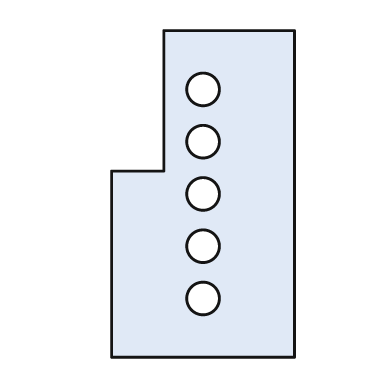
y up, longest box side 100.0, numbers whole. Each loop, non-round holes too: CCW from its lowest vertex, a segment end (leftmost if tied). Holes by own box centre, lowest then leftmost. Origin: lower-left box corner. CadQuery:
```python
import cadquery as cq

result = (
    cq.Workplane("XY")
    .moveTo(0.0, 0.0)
    .lineTo(56.0, 0.0)
    .lineTo(56.0, 100.0)
    .lineTo(16.0, 100.0)
    .lineTo(16.0, 57.0)
    .lineTo(0.0, 57.0)
    .close()
    .moveTo(28.0, 18.0)
    .circle(5.0)
    .moveTo(28.0, 34.0)
    .circle(5.0)
    .moveTo(28.0, 50.0)
    .circle(5.0)
    .moveTo(28.0, 66.0)
    .circle(5.0)
    .moveTo(28.0, 82.0)
    .circle(5.0)
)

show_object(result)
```